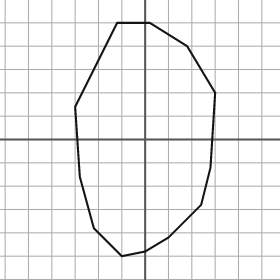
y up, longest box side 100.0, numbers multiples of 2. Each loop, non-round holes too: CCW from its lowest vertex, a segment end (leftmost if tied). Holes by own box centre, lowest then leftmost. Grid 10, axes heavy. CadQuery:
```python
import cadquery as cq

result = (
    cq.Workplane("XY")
    .moveTo(-10.0, -50.0)
    .lineTo(0.0, -48.0)
    .lineTo(10.0, -42.0)
    .lineTo(24.0, -28.0)
    .lineTo(28.0, -12.0)
    .lineTo(30.0, 20.0)
    .lineTo(18.0, 40.0)
    .lineTo(2.0, 50.0)
    .lineTo(-12.0, 50.0)
    .lineTo(-30.0, 14.0)
    .lineTo(-28.0, -16.0)
    .lineTo(-22.0, -38.0)
    .close()
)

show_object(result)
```